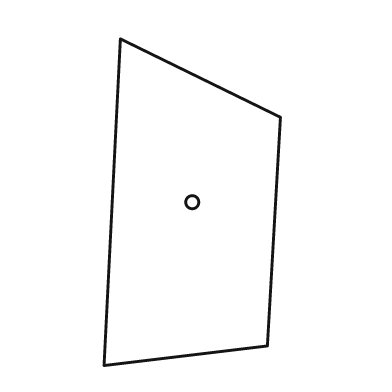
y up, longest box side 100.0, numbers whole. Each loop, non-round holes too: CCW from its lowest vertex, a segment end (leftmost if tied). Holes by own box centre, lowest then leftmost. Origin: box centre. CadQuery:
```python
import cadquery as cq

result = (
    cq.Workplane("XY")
    .moveTo(-27.0, -50.0)
    .lineTo(23.0, -44.0)
    .lineTo(27.0, 26.0)
    .lineTo(-22.0, 50.0)
    .close()
    .moveTo(0.0, 0.0)
    .circle(2.0)
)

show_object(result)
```